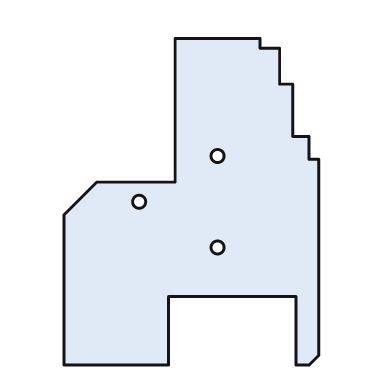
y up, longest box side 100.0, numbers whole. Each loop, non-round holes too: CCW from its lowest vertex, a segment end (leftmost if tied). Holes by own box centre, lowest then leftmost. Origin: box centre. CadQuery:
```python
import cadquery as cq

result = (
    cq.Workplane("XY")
    .moveTo(-39.0, -50.0)
    .lineTo(-7.0, -50.0)
    .lineTo(-7.0, -29.0)
    .lineTo(32.0, -29.0)
    .lineTo(32.0, -50.0)
    .lineTo(36.0, -50.0)
    .lineTo(39.0, -47.0)
    .lineTo(39.0, 13.0)
    .lineTo(36.0, 13.0)
    .lineTo(36.0, 20.0)
    .lineTo(31.0, 20.0)
    .lineTo(31.0, 36.0)
    .lineTo(27.0, 36.0)
    .lineTo(27.0, 47.0)
    .lineTo(21.0, 47.0)
    .lineTo(21.0, 50.0)
    .lineTo(-5.0, 50.0)
    .lineTo(-5.0, 6.0)
    .lineTo(-29.0, 6.0)
    .lineTo(-39.0, -4.0)
    .close()
    .moveTo(8.0, -14.0)
    .circle(2.0)
    .moveTo(-16.0, 0.0)
    .circle(2.0)
    .moveTo(8.0, 14.0)
    .circle(2.0)
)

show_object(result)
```